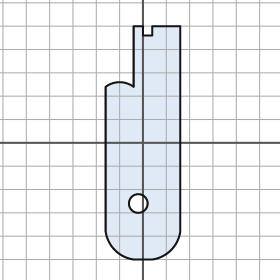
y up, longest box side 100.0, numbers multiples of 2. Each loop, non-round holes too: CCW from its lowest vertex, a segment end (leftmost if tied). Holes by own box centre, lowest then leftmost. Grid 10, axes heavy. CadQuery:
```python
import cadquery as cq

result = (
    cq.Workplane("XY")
    .moveTo(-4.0, -50.0)
    .lineTo(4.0, -50.0)
    .threePointArc((12.0, -46.0), (16.0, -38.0))
    .lineTo(16.0, 50.0)
    .lineTo(4.0, 50.0)
    .lineTo(4.0, 46.0)
    .lineTo(0.0, 46.0)
    .lineTo(0.0, 50.0)
    .lineTo(-4.0, 50.0)
    .lineTo(-4.0, 24.0)
    .threePointArc((-10.0, 26.0), (-16.0, 24.0))
    .lineTo(-16.0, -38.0)
    .threePointArc((-12.0, -46.0), (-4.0, -50.0))
    .close()
    .moveTo(-2.0, -26.0)
    .circle(4.0)
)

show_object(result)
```